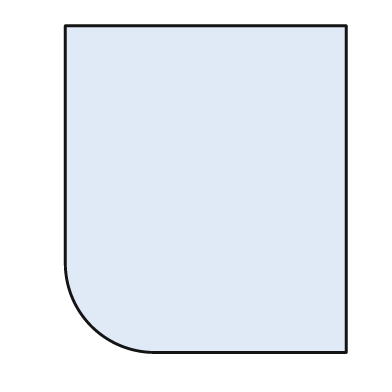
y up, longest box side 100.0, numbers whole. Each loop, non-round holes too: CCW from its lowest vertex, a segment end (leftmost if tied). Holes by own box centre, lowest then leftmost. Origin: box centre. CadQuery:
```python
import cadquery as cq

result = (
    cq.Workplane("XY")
    .moveTo(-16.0, -50.0)
    .lineTo(43.0, -50.0)
    .lineTo(43.0, 50.0)
    .lineTo(-43.0, 50.0)
    .lineTo(-43.0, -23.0)
    .threePointArc((-35.0, -42.0), (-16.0, -50.0))
    .close()
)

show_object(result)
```